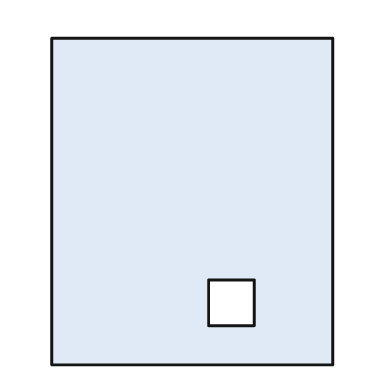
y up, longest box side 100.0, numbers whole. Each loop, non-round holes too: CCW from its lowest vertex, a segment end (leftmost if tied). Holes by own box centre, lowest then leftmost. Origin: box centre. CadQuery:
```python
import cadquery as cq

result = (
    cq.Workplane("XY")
    .moveTo(-43.0, -50.0)
    .lineTo(43.0, -50.0)
    .lineTo(43.0, 50.0)
    .lineTo(-43.0, 50.0)
    .close()
    .moveTo(5.0, -38.0)
    .lineTo(19.0, -38.0)
    .lineTo(19.0, -24.0)
    .lineTo(5.0, -24.0)
    .close()
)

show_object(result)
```